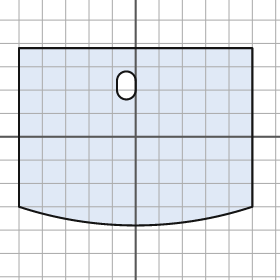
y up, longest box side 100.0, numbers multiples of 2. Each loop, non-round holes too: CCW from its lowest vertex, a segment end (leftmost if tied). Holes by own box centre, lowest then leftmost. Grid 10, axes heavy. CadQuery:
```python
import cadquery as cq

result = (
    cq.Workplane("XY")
    .moveTo(-50.0, -30.0)
    .threePointArc((0.0, -38.0), (50.0, -30.0))
    .lineTo(50.0, 38.0)
    .lineTo(-50.0, 38.0)
    .close()
    .moveTo(-8.0, 20.0)
    .threePointArc((-4.0, 16.0), (0.0, 20.0))
    .lineTo(0.0, 24.0)
    .threePointArc((-4.0, 28.0), (-8.0, 24.0))
    .close()
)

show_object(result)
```